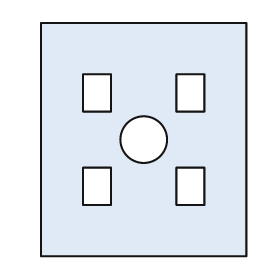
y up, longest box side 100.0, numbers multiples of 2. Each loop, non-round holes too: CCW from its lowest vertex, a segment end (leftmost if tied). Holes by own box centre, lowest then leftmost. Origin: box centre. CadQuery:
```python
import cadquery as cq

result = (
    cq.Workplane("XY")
    .moveTo(-44.0, -50.0)
    .lineTo(44.0, -50.0)
    .lineTo(44.0, 50.0)
    .lineTo(-44.0, 50.0)
    .close()
    .moveTo(-26.0, -28.0)
    .lineTo(-14.0, -28.0)
    .lineTo(-14.0, -12.0)
    .lineTo(-26.0, -12.0)
    .close()
    .moveTo(14.0, -28.0)
    .lineTo(26.0, -28.0)
    .lineTo(26.0, -12.0)
    .lineTo(14.0, -12.0)
    .close()
    .moveTo(0.0, 0.0)
    .circle(10.0)
    .moveTo(-26.0, 12.0)
    .lineTo(-14.0, 12.0)
    .lineTo(-14.0, 28.0)
    .lineTo(-26.0, 28.0)
    .close()
    .moveTo(14.0, 12.0)
    .lineTo(26.0, 12.0)
    .lineTo(26.0, 28.0)
    .lineTo(14.0, 28.0)
    .close()
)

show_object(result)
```